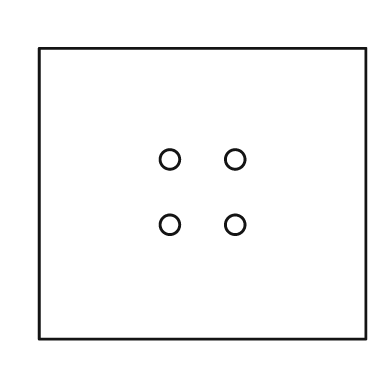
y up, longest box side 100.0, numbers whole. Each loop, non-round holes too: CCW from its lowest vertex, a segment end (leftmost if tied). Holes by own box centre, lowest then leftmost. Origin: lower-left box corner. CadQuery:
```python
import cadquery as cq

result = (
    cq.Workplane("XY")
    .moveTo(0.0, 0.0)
    .lineTo(100.0, 0.0)
    .lineTo(100.0, 89.0)
    .lineTo(0.0, 89.0)
    .close()
    .moveTo(40.0, 35.0)
    .circle(3.0)
    .moveTo(60.0, 35.0)
    .circle(3.0)
    .moveTo(40.0, 55.0)
    .circle(3.0)
    .moveTo(60.0, 55.0)
    .circle(3.0)
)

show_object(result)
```